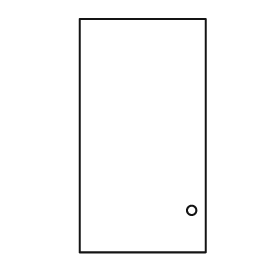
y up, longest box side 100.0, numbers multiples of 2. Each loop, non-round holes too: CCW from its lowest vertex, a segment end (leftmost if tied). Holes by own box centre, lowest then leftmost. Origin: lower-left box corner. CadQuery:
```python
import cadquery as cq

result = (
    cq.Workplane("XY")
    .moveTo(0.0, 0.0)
    .lineTo(54.0, 0.0)
    .lineTo(54.0, 100.0)
    .lineTo(0.0, 100.0)
    .close()
    .moveTo(48.0, 18.0)
    .circle(2.0)
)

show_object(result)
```